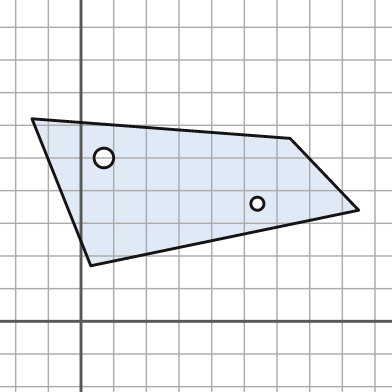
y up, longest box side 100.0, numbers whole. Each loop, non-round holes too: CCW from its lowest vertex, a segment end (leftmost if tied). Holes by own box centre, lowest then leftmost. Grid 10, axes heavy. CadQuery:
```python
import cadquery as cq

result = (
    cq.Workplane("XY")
    .moveTo(3.0, 17.0)
    .lineTo(85.0, 34.0)
    .lineTo(64.0, 56.0)
    .lineTo(-15.0, 62.0)
    .close()
    .moveTo(54.0, 36.0)
    .circle(2.0)
    .moveTo(7.0, 50.0)
    .circle(3.0)
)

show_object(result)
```